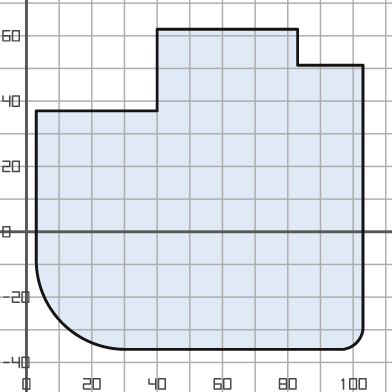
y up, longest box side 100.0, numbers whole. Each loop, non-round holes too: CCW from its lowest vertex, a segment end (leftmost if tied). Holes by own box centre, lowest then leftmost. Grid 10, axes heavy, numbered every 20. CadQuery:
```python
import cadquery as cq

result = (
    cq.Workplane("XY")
    .moveTo(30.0, -36.0)
    .lineTo(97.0, -36.0)
    .threePointArc((101.0, -34.0), (103.0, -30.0))
    .lineTo(103.0, 51.0)
    .lineTo(83.0, 51.0)
    .lineTo(83.0, 62.0)
    .lineTo(40.0, 62.0)
    .lineTo(40.0, 37.0)
    .lineTo(3.0, 37.0)
    .lineTo(3.0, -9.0)
    .threePointArc((11.0, -28.0), (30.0, -36.0))
    .close()
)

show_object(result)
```